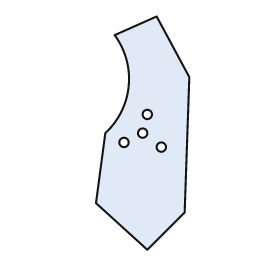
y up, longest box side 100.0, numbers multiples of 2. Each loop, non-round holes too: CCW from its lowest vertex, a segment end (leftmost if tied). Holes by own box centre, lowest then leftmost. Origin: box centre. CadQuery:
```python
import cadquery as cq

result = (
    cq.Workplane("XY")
    .moveTo(2.0, -50.0)
    .lineTo(18.0, -34.0)
    .lineTo(20.0, 24.0)
    .lineTo(6.0, 50.0)
    .lineTo(-12.0, 42.0)
    .threePointArc((-6.0, 20.0), (-16.0, 0.0))
    .lineTo(-20.0, -30.0)
    .close()
    .moveTo(8.0, -6.0)
    .circle(2.0)
    .moveTo(-8.0, -4.0)
    .circle(2.0)
    .moveTo(0.0, 0.0)
    .circle(2.0)
    .moveTo(2.0, 8.0)
    .circle(2.0)
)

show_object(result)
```